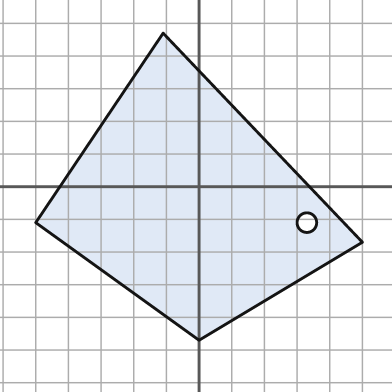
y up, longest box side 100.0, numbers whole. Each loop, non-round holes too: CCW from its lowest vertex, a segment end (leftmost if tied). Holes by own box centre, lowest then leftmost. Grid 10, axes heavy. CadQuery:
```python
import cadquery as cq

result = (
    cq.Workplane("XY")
    .moveTo(0.0, -47.0)
    .lineTo(50.0, -17.0)
    .lineTo(-11.0, 47.0)
    .lineTo(-50.0, -11.0)
    .close()
    .moveTo(33.0, -11.0)
    .circle(3.0)
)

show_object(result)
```